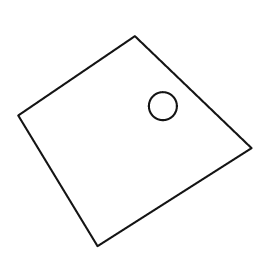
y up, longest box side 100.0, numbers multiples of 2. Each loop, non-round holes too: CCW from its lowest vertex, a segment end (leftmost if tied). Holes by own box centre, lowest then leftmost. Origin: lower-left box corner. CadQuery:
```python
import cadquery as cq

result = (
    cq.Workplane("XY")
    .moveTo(34.0, 0.0)
    .lineTo(100.0, 42.0)
    .lineTo(50.0, 90.0)
    .lineTo(0.0, 56.0)
    .close()
    .moveTo(62.0, 60.0)
    .circle(6.0)
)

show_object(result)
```